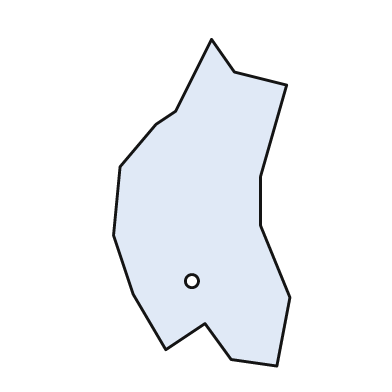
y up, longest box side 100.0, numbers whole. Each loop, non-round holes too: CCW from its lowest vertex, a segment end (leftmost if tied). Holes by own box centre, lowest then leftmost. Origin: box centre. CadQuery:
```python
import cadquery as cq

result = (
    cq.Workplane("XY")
    .moveTo(23.0, -50.0)
    .lineTo(27.0, -29.0)
    .lineTo(18.0, -7.0)
    .lineTo(18.0, 8.0)
    .lineTo(26.0, 36.0)
    .lineTo(10.0, 40.0)
    .lineTo(3.0, 50.0)
    .lineTo(-8.0, 28.0)
    .lineTo(-14.0, 24.0)
    .lineTo(-25.0, 11.0)
    .lineTo(-27.0, -10.0)
    .lineTo(-21.0, -28.0)
    .lineTo(-11.0, -45.0)
    .lineTo(1.0, -37.0)
    .lineTo(9.0, -48.0)
    .close()
    .moveTo(-3.0, -24.0)
    .circle(2.0)
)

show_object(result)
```